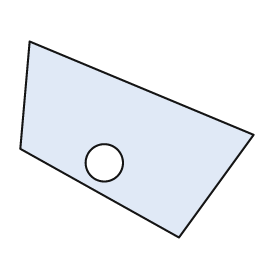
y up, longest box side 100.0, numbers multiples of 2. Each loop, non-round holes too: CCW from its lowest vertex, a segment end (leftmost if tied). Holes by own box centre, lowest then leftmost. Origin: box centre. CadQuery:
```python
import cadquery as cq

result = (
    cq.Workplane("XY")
    .moveTo(18.0, -42.0)
    .lineTo(50.0, 2.0)
    .lineTo(-46.0, 42.0)
    .lineTo(-50.0, -4.0)
    .close()
    .moveTo(-14.0, -10.0)
    .circle(8.0)
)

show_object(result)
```